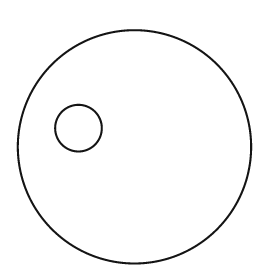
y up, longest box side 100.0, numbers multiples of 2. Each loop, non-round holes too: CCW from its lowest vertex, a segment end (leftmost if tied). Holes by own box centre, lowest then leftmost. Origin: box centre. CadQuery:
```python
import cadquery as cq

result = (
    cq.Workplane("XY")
    .moveTo(0.0, 0.0)
    .circle(50.0)
    .moveTo(-24.0, 8.0)
    .circle(10.0)
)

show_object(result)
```